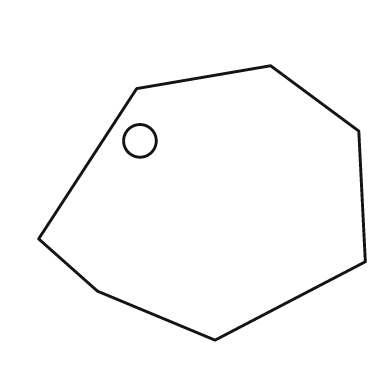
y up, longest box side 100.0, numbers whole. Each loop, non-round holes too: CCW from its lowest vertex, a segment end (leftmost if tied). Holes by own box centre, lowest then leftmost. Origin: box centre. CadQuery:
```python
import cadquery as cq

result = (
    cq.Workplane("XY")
    .moveTo(4.0, -42.0)
    .lineTo(50.0, -18.0)
    .lineTo(48.0, 22.0)
    .lineTo(21.0, 42.0)
    .lineTo(-20.0, 35.0)
    .lineTo(-50.0, -11.0)
    .lineTo(-32.0, -27.0)
    .close()
    .moveTo(-19.0, 19.0)
    .circle(5.0)
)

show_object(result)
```